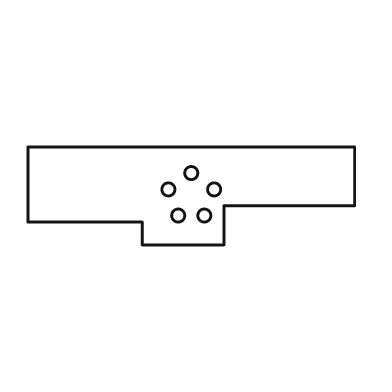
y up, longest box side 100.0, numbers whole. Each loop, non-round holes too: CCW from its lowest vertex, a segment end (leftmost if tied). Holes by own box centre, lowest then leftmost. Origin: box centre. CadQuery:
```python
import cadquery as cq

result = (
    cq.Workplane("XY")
    .moveTo(-15.0, -15.0)
    .lineTo(10.0, -15.0)
    .lineTo(10.0, -3.0)
    .lineTo(50.0, -3.0)
    .lineTo(50.0, 15.0)
    .lineTo(-50.0, 15.0)
    .lineTo(-50.0, -8.0)
    .lineTo(-15.0, -8.0)
    .close()
    .moveTo(-4.0, -6.0)
    .circle(2.0)
    .moveTo(4.0, -6.0)
    .circle(2.0)
    .moveTo(-7.0, 2.0)
    .circle(2.0)
    .moveTo(7.0, 2.0)
    .circle(2.0)
    .moveTo(0.0, 7.0)
    .circle(2.0)
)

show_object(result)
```